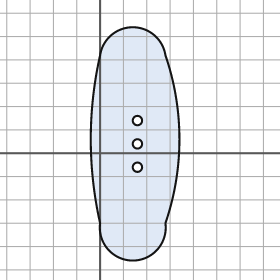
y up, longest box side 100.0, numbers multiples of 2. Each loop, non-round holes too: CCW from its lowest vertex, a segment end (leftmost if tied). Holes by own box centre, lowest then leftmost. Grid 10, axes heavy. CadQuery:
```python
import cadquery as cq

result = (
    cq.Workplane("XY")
    .moveTo(0.0, -30.0)
    .threePointArc((14.0, -46.0), (28.0, -30.0))
    .threePointArc((34.0, 6.0), (28.0, 42.0))
    .threePointArc((14.0, 54.0), (0.0, 42.0))
    .threePointArc((-4.0, 6.0), (0.0, -30.0))
    .close()
    .moveTo(16.0, -6.0)
    .circle(2.0)
    .moveTo(16.0, 4.0)
    .circle(2.0)
    .moveTo(16.0, 14.0)
    .circle(2.0)
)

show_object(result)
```